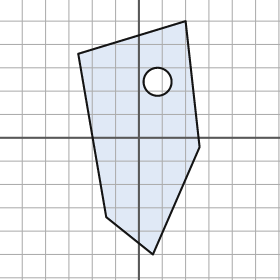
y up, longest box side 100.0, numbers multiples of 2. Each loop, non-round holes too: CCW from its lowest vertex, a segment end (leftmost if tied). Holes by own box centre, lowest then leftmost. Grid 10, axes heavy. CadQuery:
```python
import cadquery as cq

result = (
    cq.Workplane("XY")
    .moveTo(6.0, -50.0)
    .lineTo(26.0, -4.0)
    .lineTo(20.0, 50.0)
    .lineTo(-26.0, 36.0)
    .lineTo(-14.0, -34.0)
    .close()
    .moveTo(8.0, 24.0)
    .circle(6.0)
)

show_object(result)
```